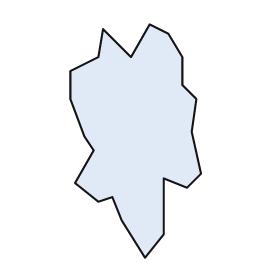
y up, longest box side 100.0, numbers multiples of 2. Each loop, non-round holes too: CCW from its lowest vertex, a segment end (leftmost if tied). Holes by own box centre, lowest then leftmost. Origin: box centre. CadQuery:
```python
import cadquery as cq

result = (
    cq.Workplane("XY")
    .moveTo(4.0, -50.0)
    .lineTo(12.0, -40.0)
    .lineTo(12.0, -16.0)
    .lineTo(22.0, -20.0)
    .lineTo(28.0, -14.0)
    .lineTo(24.0, 4.0)
    .lineTo(26.0, 18.0)
    .lineTo(20.0, 24.0)
    .lineTo(20.0, 36.0)
    .lineTo(14.0, 46.0)
    .lineTo(6.0, 50.0)
    .lineTo(-2.0, 36.0)
    .lineTo(-14.0, 48.0)
    .lineTo(-16.0, 36.0)
    .lineTo(-28.0, 30.0)
    .lineTo(-28.0, 18.0)
    .lineTo(-22.0, 2.0)
    .lineTo(-18.0, -4.0)
    .lineTo(-26.0, -18.0)
    .lineTo(-16.0, -26.0)
    .lineTo(-10.0, -24.0)
    .lineTo(-6.0, -34.0)
    .close()
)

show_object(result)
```